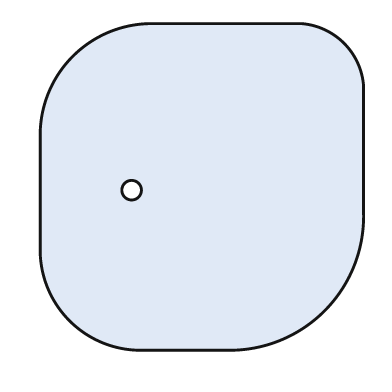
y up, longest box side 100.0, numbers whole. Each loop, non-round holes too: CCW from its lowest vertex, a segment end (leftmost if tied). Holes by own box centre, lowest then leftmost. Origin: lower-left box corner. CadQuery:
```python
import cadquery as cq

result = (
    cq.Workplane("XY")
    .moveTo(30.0, 0.0)
    .lineTo(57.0, 0.0)
    .threePointArc((87.0, 12.0), (99.0, 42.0))
    .lineTo(99.0, 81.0)
    .threePointArc((93.0, 94.0), (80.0, 100.0))
    .lineTo(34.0, 100.0)
    .threePointArc((10.0, 90.0), (0.0, 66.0))
    .lineTo(0.0, 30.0)
    .threePointArc((9.0, 9.0), (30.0, 0.0))
    .close()
    .moveTo(28.0, 49.0)
    .circle(3.0)
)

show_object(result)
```